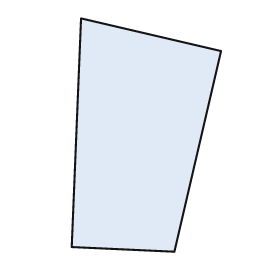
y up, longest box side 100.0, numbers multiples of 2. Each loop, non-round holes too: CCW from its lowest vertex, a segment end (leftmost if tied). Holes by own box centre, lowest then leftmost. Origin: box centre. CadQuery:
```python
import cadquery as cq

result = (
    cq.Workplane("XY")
    .moveTo(12.0, -50.0)
    .lineTo(32.0, 36.0)
    .lineTo(-28.0, 50.0)
    .lineTo(-32.0, -48.0)
    .close()
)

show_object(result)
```